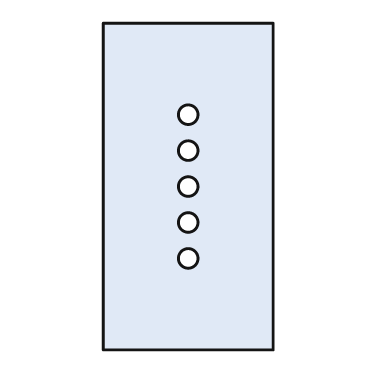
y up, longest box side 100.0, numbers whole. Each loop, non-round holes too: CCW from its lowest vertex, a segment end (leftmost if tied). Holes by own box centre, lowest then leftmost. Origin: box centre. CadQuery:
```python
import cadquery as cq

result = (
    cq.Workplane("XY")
    .moveTo(-26.0, -50.0)
    .lineTo(26.0, -50.0)
    .lineTo(26.0, 50.0)
    .lineTo(-26.0, 50.0)
    .close()
    .moveTo(0.0, -22.0)
    .circle(3.0)
    .moveTo(0.0, -11.0)
    .circle(3.0)
    .moveTo(0.0, 0.0)
    .circle(3.0)
    .moveTo(0.0, 11.0)
    .circle(3.0)
    .moveTo(0.0, 22.0)
    .circle(3.0)
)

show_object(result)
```